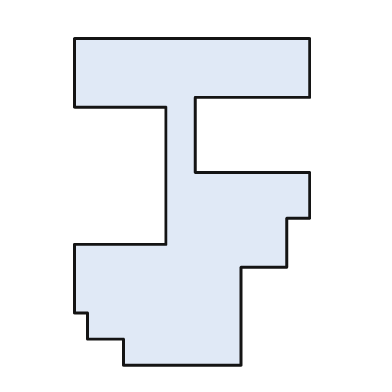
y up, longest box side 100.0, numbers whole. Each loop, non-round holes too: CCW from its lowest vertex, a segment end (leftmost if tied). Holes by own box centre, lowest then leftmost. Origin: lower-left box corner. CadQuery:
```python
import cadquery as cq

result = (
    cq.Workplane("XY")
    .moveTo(15.0, 0.0)
    .lineTo(51.0, 0.0)
    .lineTo(51.0, 30.0)
    .lineTo(65.0, 30.0)
    .lineTo(65.0, 45.0)
    .lineTo(72.0, 45.0)
    .lineTo(72.0, 59.0)
    .lineTo(37.0, 59.0)
    .lineTo(37.0, 82.0)
    .lineTo(72.0, 82.0)
    .lineTo(72.0, 100.0)
    .lineTo(0.0, 100.0)
    .lineTo(0.0, 79.0)
    .lineTo(28.0, 79.0)
    .lineTo(28.0, 37.0)
    .lineTo(0.0, 37.0)
    .lineTo(0.0, 16.0)
    .lineTo(4.0, 16.0)
    .lineTo(4.0, 8.0)
    .lineTo(15.0, 8.0)
    .close()
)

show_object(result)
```